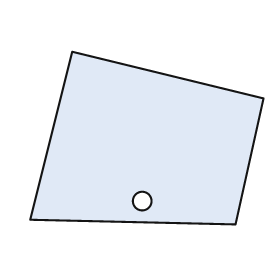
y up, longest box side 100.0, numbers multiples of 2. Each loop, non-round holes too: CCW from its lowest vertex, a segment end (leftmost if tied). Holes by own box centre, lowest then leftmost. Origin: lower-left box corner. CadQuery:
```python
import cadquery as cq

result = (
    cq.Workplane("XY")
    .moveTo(88.0, 0.0)
    .lineTo(100.0, 54.0)
    .lineTo(18.0, 74.0)
    .lineTo(0.0, 2.0)
    .close()
    .moveTo(48.0, 10.0)
    .circle(4.0)
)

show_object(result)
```